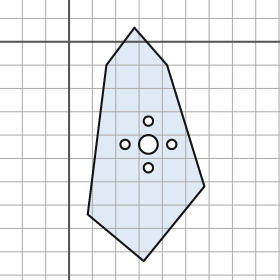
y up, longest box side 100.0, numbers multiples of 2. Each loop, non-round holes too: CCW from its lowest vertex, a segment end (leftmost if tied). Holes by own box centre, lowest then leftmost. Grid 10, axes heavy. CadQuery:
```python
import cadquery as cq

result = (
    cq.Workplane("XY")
    .moveTo(32.0, -94.0)
    .lineTo(58.0, -62.0)
    .lineTo(42.0, -10.0)
    .lineTo(28.0, 6.0)
    .lineTo(16.0, -10.0)
    .lineTo(8.0, -74.0)
    .close()
    .moveTo(34.0, -54.0)
    .circle(2.0)
    .moveTo(24.0, -44.0)
    .circle(2.0)
    .moveTo(34.0, -44.0)
    .circle(4.0)
    .moveTo(44.0, -44.0)
    .circle(2.0)
    .moveTo(34.0, -34.0)
    .circle(2.0)
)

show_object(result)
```